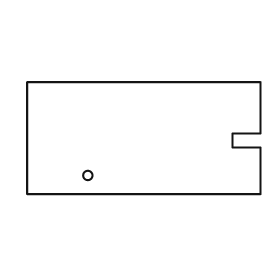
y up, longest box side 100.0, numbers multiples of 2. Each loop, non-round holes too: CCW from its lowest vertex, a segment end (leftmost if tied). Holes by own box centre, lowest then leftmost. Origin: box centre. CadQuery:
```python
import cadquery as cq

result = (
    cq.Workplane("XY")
    .moveTo(-50.0, -24.0)
    .lineTo(50.0, -24.0)
    .lineTo(50.0, -4.0)
    .lineTo(38.0, -4.0)
    .lineTo(38.0, 2.0)
    .lineTo(50.0, 2.0)
    .lineTo(50.0, 24.0)
    .lineTo(-50.0, 24.0)
    .close()
    .moveTo(-24.0, -16.0)
    .circle(2.0)
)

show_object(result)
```